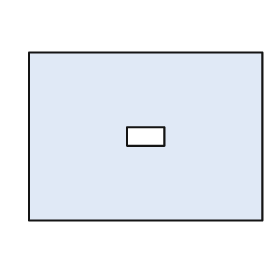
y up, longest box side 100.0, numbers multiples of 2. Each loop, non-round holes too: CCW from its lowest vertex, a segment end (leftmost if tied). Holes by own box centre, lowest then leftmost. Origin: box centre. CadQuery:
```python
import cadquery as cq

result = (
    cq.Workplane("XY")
    .moveTo(-50.0, -36.0)
    .lineTo(50.0, -36.0)
    .lineTo(50.0, 36.0)
    .lineTo(-50.0, 36.0)
    .close()
    .moveTo(-8.0, -4.0)
    .lineTo(8.0, -4.0)
    .lineTo(8.0, 4.0)
    .lineTo(-8.0, 4.0)
    .close()
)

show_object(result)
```